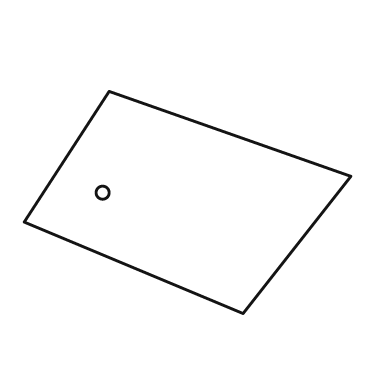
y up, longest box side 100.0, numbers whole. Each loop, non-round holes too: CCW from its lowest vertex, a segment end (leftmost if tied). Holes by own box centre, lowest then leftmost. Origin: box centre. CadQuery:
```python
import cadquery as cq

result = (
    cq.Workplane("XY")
    .moveTo(17.0, -34.0)
    .lineTo(50.0, 8.0)
    .lineTo(-24.0, 34.0)
    .lineTo(-50.0, -6.0)
    .close()
    .moveTo(-26.0, 3.0)
    .circle(2.0)
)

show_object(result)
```